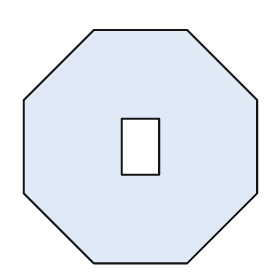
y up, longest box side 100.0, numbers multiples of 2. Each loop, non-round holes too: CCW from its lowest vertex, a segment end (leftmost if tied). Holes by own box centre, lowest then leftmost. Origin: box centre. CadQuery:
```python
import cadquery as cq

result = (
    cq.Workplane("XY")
    .moveTo(-20.0, -50.0)
    .lineTo(20.0, -50.0)
    .lineTo(50.0, -20.0)
    .lineTo(50.0, 20.0)
    .lineTo(20.0, 50.0)
    .lineTo(-20.0, 50.0)
    .lineTo(-50.0, 20.0)
    .lineTo(-50.0, -20.0)
    .close()
    .moveTo(-8.0, -12.0)
    .lineTo(8.0, -12.0)
    .lineTo(8.0, 12.0)
    .lineTo(-8.0, 12.0)
    .close()
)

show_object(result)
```